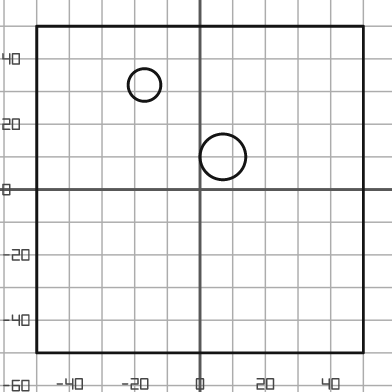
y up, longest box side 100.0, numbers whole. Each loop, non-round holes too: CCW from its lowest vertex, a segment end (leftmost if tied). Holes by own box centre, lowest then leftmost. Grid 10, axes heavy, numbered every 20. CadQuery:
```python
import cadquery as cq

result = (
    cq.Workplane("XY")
    .moveTo(-50.0, -50.0)
    .lineTo(50.0, -50.0)
    .lineTo(50.0, 50.0)
    .lineTo(-50.0, 50.0)
    .close()
    .moveTo(7.0, 10.0)
    .circle(7.0)
    .moveTo(-17.0, 32.0)
    .circle(5.0)
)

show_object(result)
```